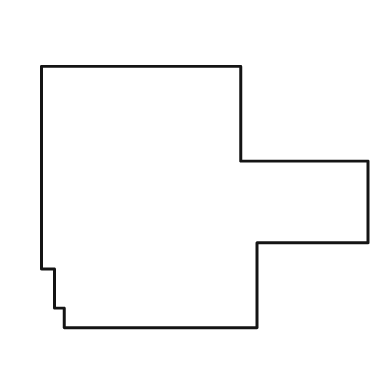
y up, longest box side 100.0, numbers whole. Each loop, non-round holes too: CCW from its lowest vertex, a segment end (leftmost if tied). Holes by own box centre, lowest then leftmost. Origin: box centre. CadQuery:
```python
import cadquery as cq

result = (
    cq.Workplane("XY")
    .moveTo(-43.0, -40.0)
    .lineTo(16.0, -40.0)
    .lineTo(16.0, -14.0)
    .lineTo(50.0, -14.0)
    .lineTo(50.0, 11.0)
    .lineTo(11.0, 11.0)
    .lineTo(11.0, 40.0)
    .lineTo(-50.0, 40.0)
    .lineTo(-50.0, -22.0)
    .lineTo(-46.0, -22.0)
    .lineTo(-46.0, -34.0)
    .lineTo(-43.0, -34.0)
    .close()
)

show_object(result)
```